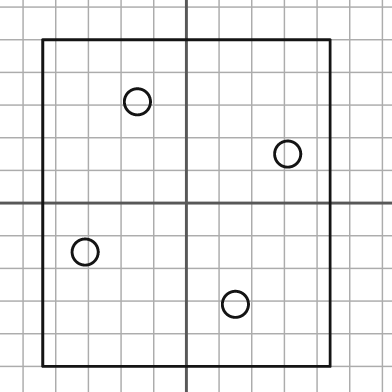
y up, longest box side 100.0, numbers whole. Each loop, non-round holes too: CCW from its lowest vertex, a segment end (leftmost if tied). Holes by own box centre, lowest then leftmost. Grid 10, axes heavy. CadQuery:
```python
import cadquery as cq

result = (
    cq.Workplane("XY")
    .moveTo(-44.0, -50.0)
    .lineTo(44.0, -50.0)
    .lineTo(44.0, 50.0)
    .lineTo(-44.0, 50.0)
    .close()
    .moveTo(15.0, -31.0)
    .circle(4.0)
    .moveTo(-31.0, -15.0)
    .circle(4.0)
    .moveTo(31.0, 15.0)
    .circle(4.0)
    .moveTo(-15.0, 31.0)
    .circle(4.0)
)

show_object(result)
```